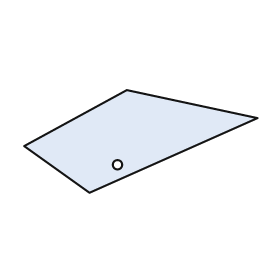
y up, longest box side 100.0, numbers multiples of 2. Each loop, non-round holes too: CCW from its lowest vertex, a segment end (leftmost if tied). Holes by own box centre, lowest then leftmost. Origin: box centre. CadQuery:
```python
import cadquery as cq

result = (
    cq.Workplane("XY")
    .moveTo(-22.0, -22.0)
    .lineTo(50.0, 10.0)
    .lineTo(-6.0, 22.0)
    .lineTo(-50.0, -2.0)
    .close()
    .moveTo(-10.0, -10.0)
    .circle(2.0)
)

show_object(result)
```